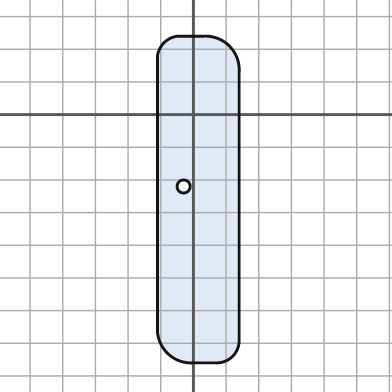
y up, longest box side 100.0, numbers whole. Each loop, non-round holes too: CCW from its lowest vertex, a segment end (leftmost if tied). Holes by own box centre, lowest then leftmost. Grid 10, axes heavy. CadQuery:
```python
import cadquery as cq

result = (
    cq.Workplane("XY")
    .moveTo(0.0, -76.0)
    .lineTo(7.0, -76.0)
    .threePointArc((12.0, -74.0), (14.0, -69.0))
    .lineTo(14.0, 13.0)
    .threePointArc((11.0, 21.0), (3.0, 24.0))
    .lineTo(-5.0, 24.0)
    .threePointArc((-9.0, 22.0), (-11.0, 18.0))
    .lineTo(-11.0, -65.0)
    .threePointArc((-8.0, -73.0), (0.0, -76.0))
    .close()
    .moveTo(-3.0, -22.0)
    .circle(2.0)
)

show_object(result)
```